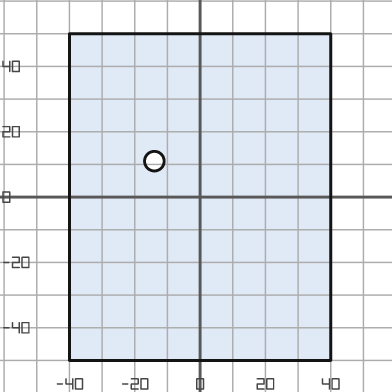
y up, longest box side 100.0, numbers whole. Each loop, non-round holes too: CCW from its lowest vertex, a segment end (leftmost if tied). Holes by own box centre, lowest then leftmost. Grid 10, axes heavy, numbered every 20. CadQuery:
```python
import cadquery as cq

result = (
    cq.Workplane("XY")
    .moveTo(-40.0, -50.0)
    .lineTo(40.0, -50.0)
    .lineTo(40.0, 50.0)
    .lineTo(-40.0, 50.0)
    .close()
    .moveTo(-14.0, 11.0)
    .circle(3.0)
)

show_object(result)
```